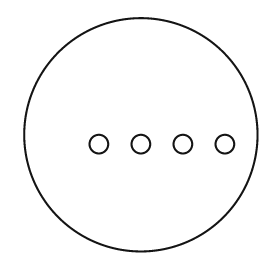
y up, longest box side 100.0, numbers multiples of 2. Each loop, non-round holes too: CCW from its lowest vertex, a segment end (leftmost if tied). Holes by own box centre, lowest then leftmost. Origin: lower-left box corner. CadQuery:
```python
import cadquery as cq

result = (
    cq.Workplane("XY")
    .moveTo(50.0, 50.0)
    .circle(50.0)
    .moveTo(32.0, 46.0)
    .circle(4.0)
    .moveTo(50.0, 46.0)
    .circle(4.0)
    .moveTo(68.0, 46.0)
    .circle(4.0)
    .moveTo(86.0, 46.0)
    .circle(4.0)
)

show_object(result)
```